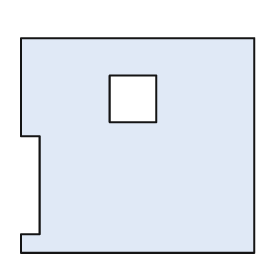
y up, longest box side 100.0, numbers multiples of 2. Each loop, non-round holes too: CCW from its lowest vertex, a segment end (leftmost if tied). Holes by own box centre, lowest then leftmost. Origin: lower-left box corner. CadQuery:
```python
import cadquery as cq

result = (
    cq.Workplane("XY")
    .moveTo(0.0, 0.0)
    .lineTo(100.0, 0.0)
    .lineTo(100.0, 92.0)
    .lineTo(0.0, 92.0)
    .lineTo(0.0, 50.0)
    .lineTo(8.0, 50.0)
    .lineTo(8.0, 8.0)
    .lineTo(0.0, 8.0)
    .close()
    .moveTo(38.0, 56.0)
    .lineTo(58.0, 56.0)
    .lineTo(58.0, 76.0)
    .lineTo(38.0, 76.0)
    .close()
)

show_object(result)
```